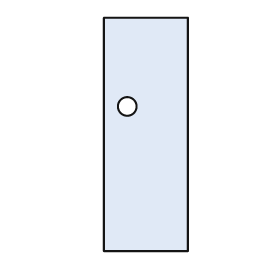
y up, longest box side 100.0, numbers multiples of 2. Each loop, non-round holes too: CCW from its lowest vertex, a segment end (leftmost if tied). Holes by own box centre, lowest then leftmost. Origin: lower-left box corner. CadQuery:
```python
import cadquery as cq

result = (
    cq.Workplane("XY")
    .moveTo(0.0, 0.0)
    .lineTo(36.0, 0.0)
    .lineTo(36.0, 100.0)
    .lineTo(0.0, 100.0)
    .close()
    .moveTo(10.0, 62.0)
    .circle(4.0)
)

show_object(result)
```